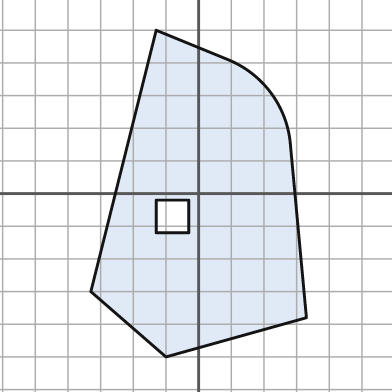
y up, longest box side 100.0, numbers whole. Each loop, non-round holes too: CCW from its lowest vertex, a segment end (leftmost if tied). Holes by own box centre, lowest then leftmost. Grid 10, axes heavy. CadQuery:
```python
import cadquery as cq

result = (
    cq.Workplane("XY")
    .moveTo(-10.0, -50.0)
    .lineTo(33.0, -38.0)
    .lineTo(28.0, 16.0)
    .threePointArc((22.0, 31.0), (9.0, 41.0))
    .lineTo(-13.0, 50.0)
    .lineTo(-33.0, -30.0)
    .close()
    .moveTo(-13.0, -12.0)
    .lineTo(-3.0, -12.0)
    .lineTo(-3.0, -2.0)
    .lineTo(-13.0, -2.0)
    .close()
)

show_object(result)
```